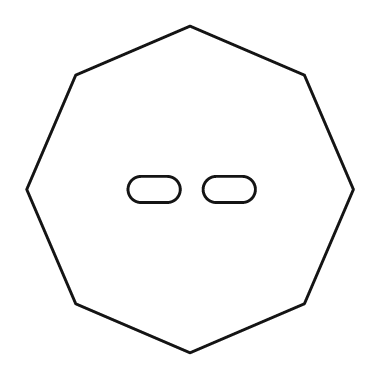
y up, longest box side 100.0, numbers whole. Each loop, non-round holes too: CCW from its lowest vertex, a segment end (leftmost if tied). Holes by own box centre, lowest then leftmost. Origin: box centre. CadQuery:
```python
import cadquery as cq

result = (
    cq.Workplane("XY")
    .moveTo(0.0, -50.0)
    .lineTo(35.0, -35.0)
    .lineTo(50.0, 0.0)
    .lineTo(35.0, 35.0)
    .lineTo(0.0, 50.0)
    .lineTo(-35.0, 35.0)
    .lineTo(-50.0, 0.0)
    .lineTo(-35.0, -35.0)
    .close()
    .moveTo(-15.0, -4.0)
    .lineTo(-7.0, -4.0)
    .threePointArc((-3.0, 0.0), (-7.0, 4.0))
    .lineTo(-15.0, 4.0)
    .threePointArc((-19.0, 0.0), (-15.0, -4.0))
    .close()
    .moveTo(8.0, -4.0)
    .lineTo(16.0, -4.0)
    .threePointArc((20.0, 0.0), (16.0, 4.0))
    .lineTo(8.0, 4.0)
    .threePointArc((4.0, 0.0), (8.0, -4.0))
    .close()
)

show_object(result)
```